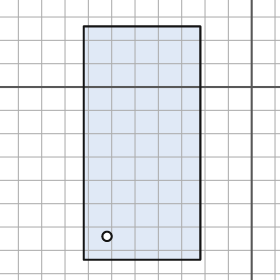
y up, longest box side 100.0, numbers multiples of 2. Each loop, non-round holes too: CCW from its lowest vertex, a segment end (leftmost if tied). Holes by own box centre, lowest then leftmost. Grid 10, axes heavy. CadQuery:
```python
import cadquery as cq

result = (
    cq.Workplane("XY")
    .moveTo(-72.0, -74.0)
    .lineTo(-22.0, -74.0)
    .lineTo(-22.0, 26.0)
    .lineTo(-72.0, 26.0)
    .close()
    .moveTo(-62.0, -64.0)
    .circle(2.0)
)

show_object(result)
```